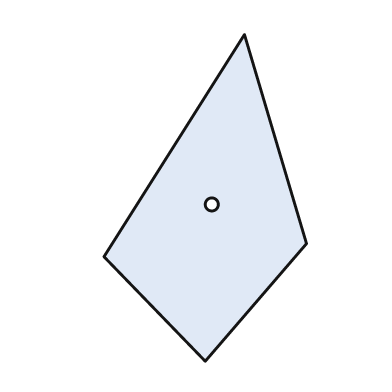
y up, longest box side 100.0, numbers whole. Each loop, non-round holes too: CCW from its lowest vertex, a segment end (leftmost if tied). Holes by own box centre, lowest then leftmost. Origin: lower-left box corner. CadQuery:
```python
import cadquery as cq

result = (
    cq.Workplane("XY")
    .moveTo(31.0, 0.0)
    .lineTo(62.0, 36.0)
    .lineTo(43.0, 100.0)
    .lineTo(0.0, 32.0)
    .close()
    .moveTo(33.0, 48.0)
    .circle(2.0)
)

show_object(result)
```